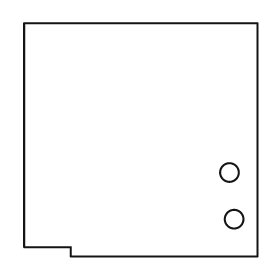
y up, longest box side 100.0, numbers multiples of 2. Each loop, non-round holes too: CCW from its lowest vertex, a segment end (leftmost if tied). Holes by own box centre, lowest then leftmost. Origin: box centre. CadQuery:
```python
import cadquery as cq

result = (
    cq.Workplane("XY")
    .moveTo(-30.0, -50.0)
    .lineTo(50.0, -50.0)
    .lineTo(50.0, 50.0)
    .lineTo(-50.0, 50.0)
    .lineTo(-50.0, -46.0)
    .lineTo(-30.0, -46.0)
    .close()
    .moveTo(40.0, -34.0)
    .circle(4.0)
    .moveTo(38.0, -14.0)
    .circle(4.0)
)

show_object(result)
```